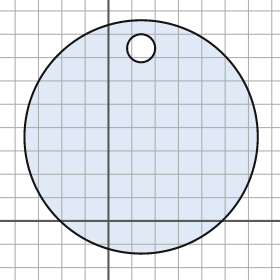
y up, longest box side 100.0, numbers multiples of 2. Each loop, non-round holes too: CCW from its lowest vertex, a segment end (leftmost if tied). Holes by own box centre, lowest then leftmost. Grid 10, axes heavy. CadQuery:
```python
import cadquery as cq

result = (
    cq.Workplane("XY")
    .moveTo(14.0, 36.0)
    .circle(50.0)
    .moveTo(14.0, 74.0)
    .circle(6.0)
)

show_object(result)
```